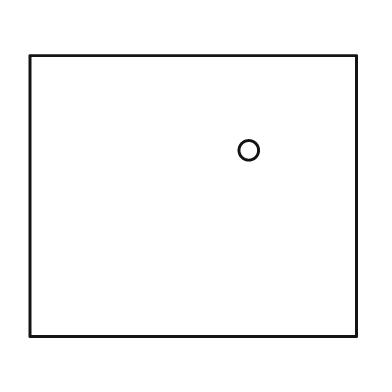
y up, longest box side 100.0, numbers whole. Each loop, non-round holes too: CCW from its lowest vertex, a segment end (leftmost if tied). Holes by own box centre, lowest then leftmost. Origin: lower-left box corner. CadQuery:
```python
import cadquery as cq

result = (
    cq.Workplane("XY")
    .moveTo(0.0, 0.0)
    .lineTo(100.0, 0.0)
    .lineTo(100.0, 86.0)
    .lineTo(0.0, 86.0)
    .close()
    .moveTo(67.0, 57.0)
    .circle(3.0)
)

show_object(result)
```